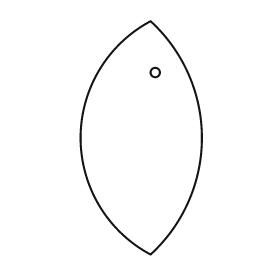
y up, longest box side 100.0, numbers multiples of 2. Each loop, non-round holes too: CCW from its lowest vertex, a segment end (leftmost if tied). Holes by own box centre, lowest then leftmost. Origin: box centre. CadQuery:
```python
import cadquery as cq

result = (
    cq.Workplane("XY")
    .moveTo(4.0, -50.0)
    .threePointArc((26.0, 0.0), (4.0, 50.0))
    .threePointArc((-26.0, 0.0), (4.0, -50.0))
    .close()
    .moveTo(6.0, 28.0)
    .circle(2.0)
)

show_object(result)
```